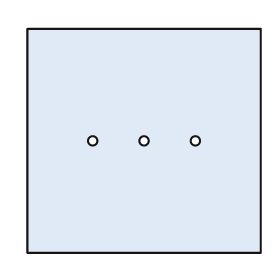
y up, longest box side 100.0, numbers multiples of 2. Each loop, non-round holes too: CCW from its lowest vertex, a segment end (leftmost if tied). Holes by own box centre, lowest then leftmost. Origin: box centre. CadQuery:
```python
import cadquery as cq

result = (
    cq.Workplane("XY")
    .moveTo(-50.0, -48.0)
    .lineTo(50.0, -48.0)
    .lineTo(50.0, 48.0)
    .lineTo(-50.0, 48.0)
    .close()
    .moveTo(-22.0, 0.0)
    .circle(2.0)
    .moveTo(0.0, 0.0)
    .circle(2.0)
    .moveTo(22.0, 0.0)
    .circle(2.0)
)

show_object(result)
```